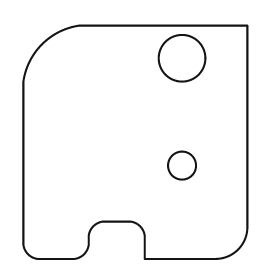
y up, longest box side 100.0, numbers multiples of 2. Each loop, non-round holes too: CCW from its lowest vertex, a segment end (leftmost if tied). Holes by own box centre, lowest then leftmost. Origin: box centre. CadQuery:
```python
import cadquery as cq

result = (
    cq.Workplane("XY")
    .moveTo(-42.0, -50.0)
    .lineTo(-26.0, -50.0)
    .threePointArc((-22.0, -48.0), (-20.0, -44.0))
    .lineTo(-20.0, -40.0)
    .threePointArc((-18.0, -36.0), (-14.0, -34.0))
    .lineTo(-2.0, -34.0)
    .threePointArc((2.0, -36.0), (4.0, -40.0))
    .lineTo(4.0, -50.0)
    .lineTo(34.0, -50.0)
    .threePointArc((44.0, -46.0), (48.0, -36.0))
    .lineTo(48.0, 50.0)
    .lineTo(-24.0, 50.0)
    .threePointArc((-40.0, 42.0), (-48.0, 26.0))
    .lineTo(-48.0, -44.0)
    .threePointArc((-46.0, -48.0), (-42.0, -50.0))
    .close()
    .moveTo(20.0, -10.0)
    .circle(6.0)
    .moveTo(20.0, 36.0)
    .circle(10.0)
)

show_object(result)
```